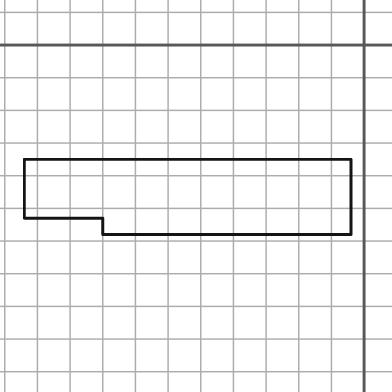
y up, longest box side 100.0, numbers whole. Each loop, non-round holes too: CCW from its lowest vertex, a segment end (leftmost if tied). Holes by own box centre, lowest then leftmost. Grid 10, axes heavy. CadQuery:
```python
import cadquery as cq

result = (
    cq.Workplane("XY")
    .moveTo(-80.0, -58.0)
    .lineTo(-4.0, -58.0)
    .lineTo(-4.0, -35.0)
    .lineTo(-104.0, -35.0)
    .lineTo(-104.0, -53.0)
    .lineTo(-80.0, -53.0)
    .close()
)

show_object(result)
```